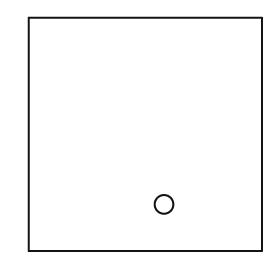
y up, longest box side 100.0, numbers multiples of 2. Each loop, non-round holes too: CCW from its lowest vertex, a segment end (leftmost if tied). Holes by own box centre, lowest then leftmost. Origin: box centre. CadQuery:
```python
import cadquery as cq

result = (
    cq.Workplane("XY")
    .moveTo(-50.0, -50.0)
    .lineTo(50.0, -50.0)
    .lineTo(50.0, 50.0)
    .lineTo(-50.0, 50.0)
    .close()
    .moveTo(8.0, -30.0)
    .circle(4.0)
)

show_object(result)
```